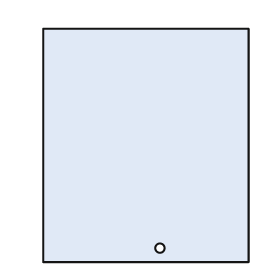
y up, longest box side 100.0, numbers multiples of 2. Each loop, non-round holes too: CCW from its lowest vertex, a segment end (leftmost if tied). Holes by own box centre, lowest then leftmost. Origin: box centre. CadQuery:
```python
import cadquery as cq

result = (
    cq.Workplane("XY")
    .moveTo(-44.0, -50.0)
    .lineTo(44.0, -50.0)
    .lineTo(44.0, 50.0)
    .lineTo(-44.0, 50.0)
    .close()
    .moveTo(6.0, -44.0)
    .circle(2.0)
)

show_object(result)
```